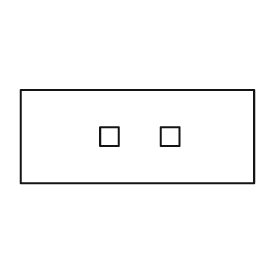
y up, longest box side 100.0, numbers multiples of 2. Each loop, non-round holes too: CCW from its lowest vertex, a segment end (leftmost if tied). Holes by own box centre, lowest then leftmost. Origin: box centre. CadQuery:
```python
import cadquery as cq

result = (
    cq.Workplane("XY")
    .moveTo(-50.0, -20.0)
    .lineTo(50.0, -20.0)
    .lineTo(50.0, 20.0)
    .lineTo(-50.0, 20.0)
    .close()
    .moveTo(-16.0, -4.0)
    .lineTo(-8.0, -4.0)
    .lineTo(-8.0, 4.0)
    .lineTo(-16.0, 4.0)
    .close()
    .moveTo(10.0, -4.0)
    .lineTo(18.0, -4.0)
    .lineTo(18.0, 4.0)
    .lineTo(10.0, 4.0)
    .close()
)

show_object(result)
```